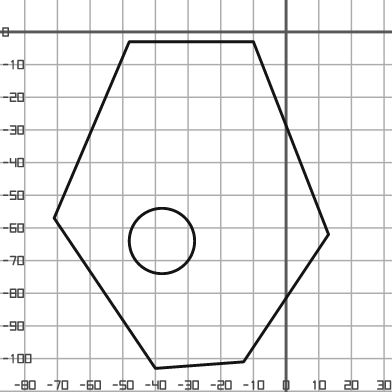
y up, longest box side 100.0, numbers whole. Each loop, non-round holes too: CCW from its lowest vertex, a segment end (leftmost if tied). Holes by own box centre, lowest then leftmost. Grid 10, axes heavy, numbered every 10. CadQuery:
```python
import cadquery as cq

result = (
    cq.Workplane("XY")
    .moveTo(-40.0, -103.0)
    .lineTo(-13.0, -101.0)
    .lineTo(13.0, -62.0)
    .lineTo(-10.0, -3.0)
    .lineTo(-48.0, -3.0)
    .lineTo(-71.0, -57.0)
    .close()
    .moveTo(-38.0, -64.0)
    .circle(10.0)
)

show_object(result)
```